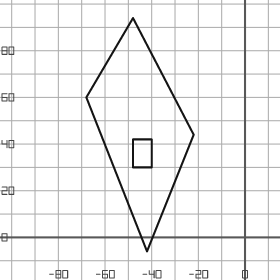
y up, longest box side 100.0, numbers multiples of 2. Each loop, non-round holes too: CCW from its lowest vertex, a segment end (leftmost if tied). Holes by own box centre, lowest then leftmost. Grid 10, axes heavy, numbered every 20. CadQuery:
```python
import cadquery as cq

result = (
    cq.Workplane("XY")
    .moveTo(-42.0, -6.0)
    .lineTo(-22.0, 44.0)
    .lineTo(-48.0, 94.0)
    .lineTo(-68.0, 60.0)
    .close()
    .moveTo(-48.0, 30.0)
    .lineTo(-40.0, 30.0)
    .lineTo(-40.0, 42.0)
    .lineTo(-48.0, 42.0)
    .close()
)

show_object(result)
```